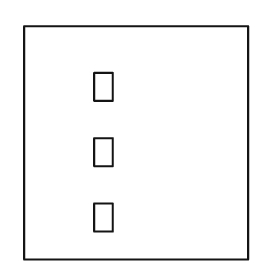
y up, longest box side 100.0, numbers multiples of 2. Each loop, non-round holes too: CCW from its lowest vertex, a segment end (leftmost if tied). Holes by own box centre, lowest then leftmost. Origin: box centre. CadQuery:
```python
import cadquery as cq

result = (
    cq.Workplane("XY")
    .moveTo(-48.0, -50.0)
    .lineTo(48.0, -50.0)
    .lineTo(48.0, 50.0)
    .lineTo(-48.0, 50.0)
    .close()
    .moveTo(-18.0, -38.0)
    .lineTo(-10.0, -38.0)
    .lineTo(-10.0, -26.0)
    .lineTo(-18.0, -26.0)
    .close()
    .moveTo(-18.0, -10.0)
    .lineTo(-10.0, -10.0)
    .lineTo(-10.0, 2.0)
    .lineTo(-18.0, 2.0)
    .close()
    .moveTo(-18.0, 18.0)
    .lineTo(-10.0, 18.0)
    .lineTo(-10.0, 30.0)
    .lineTo(-18.0, 30.0)
    .close()
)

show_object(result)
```